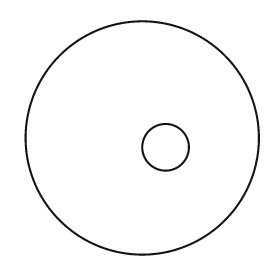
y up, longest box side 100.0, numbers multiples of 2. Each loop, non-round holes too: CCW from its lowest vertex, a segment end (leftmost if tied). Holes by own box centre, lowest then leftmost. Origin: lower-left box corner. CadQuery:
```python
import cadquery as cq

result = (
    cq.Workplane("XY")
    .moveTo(50.0, 50.0)
    .circle(50.0)
    .moveTo(60.0, 46.0)
    .circle(10.0)
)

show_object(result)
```